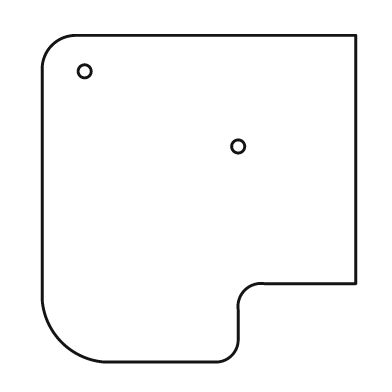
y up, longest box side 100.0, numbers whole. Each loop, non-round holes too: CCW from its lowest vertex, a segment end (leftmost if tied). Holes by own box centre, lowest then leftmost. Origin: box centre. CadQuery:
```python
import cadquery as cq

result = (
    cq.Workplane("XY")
    .moveTo(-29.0, -50.0)
    .lineTo(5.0, -50.0)
    .threePointArc((10.0, -48.0), (12.0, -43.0))
    .lineTo(12.0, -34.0)
    .threePointArc((14.0, -28.0), (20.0, -26.0))
    .lineTo(48.0, -26.0)
    .lineTo(48.0, 50.0)
    .lineTo(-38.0, 50.0)
    .threePointArc((-45.0, 47.0), (-48.0, 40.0))
    .lineTo(-48.0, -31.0)
    .threePointArc((-42.0, -44.0), (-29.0, -50.0))
    .close()
    .moveTo(12.0, 16.0)
    .circle(2.0)
    .moveTo(-35.0, 39.0)
    .circle(2.0)
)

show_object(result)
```